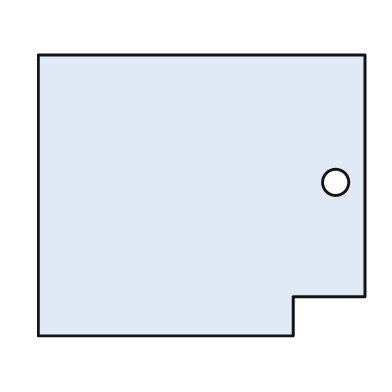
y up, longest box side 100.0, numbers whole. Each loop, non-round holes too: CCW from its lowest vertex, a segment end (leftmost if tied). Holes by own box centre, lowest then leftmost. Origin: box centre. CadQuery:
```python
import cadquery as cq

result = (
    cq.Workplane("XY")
    .moveTo(-50.0, -43.0)
    .lineTo(28.0, -43.0)
    .lineTo(28.0, -31.0)
    .lineTo(50.0, -31.0)
    .lineTo(50.0, 43.0)
    .lineTo(-50.0, 43.0)
    .close()
    .moveTo(41.0, 4.0)
    .circle(4.0)
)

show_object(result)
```